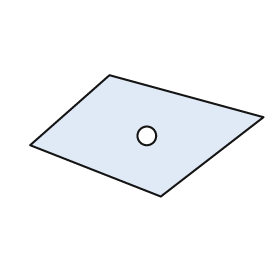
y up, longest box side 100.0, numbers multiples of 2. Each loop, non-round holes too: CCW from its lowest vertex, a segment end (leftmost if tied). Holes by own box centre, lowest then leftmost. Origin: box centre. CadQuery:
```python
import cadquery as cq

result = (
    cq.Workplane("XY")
    .moveTo(6.0, -26.0)
    .lineTo(50.0, 8.0)
    .lineTo(-16.0, 26.0)
    .lineTo(-50.0, -4.0)
    .close()
    .moveTo(0.0, 0.0)
    .circle(4.0)
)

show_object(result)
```